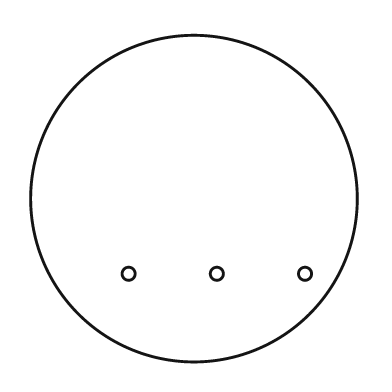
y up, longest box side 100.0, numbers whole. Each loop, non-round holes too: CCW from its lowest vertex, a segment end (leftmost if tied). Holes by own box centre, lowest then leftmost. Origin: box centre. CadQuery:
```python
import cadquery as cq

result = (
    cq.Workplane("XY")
    .moveTo(0.0, 0.0)
    .circle(50.0)
    .moveTo(-20.0, -23.0)
    .circle(2.0)
    .moveTo(7.0, -23.0)
    .circle(2.0)
    .moveTo(34.0, -23.0)
    .circle(2.0)
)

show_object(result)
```